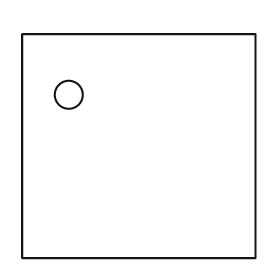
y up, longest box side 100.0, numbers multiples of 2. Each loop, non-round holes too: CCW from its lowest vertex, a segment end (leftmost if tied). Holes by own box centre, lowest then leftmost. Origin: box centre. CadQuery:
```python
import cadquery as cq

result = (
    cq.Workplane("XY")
    .moveTo(-50.0, -48.0)
    .lineTo(50.0, -48.0)
    .lineTo(50.0, 48.0)
    .lineTo(-50.0, 48.0)
    .close()
    .moveTo(-30.0, 22.0)
    .circle(6.0)
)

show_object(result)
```